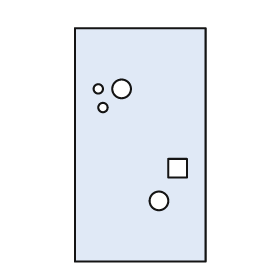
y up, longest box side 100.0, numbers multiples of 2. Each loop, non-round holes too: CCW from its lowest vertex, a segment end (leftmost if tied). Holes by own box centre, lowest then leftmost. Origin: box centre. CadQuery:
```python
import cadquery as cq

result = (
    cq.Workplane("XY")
    .moveTo(-28.0, -50.0)
    .lineTo(28.0, -50.0)
    .lineTo(28.0, 50.0)
    .lineTo(-28.0, 50.0)
    .close()
    .moveTo(8.0, -24.0)
    .circle(4.0)
    .moveTo(12.0, -14.0)
    .lineTo(20.0, -14.0)
    .lineTo(20.0, -6.0)
    .lineTo(12.0, -6.0)
    .close()
    .moveTo(-16.0, 16.0)
    .circle(2.0)
    .moveTo(-18.0, 24.0)
    .circle(2.0)
    .moveTo(-8.0, 24.0)
    .circle(4.0)
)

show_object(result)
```